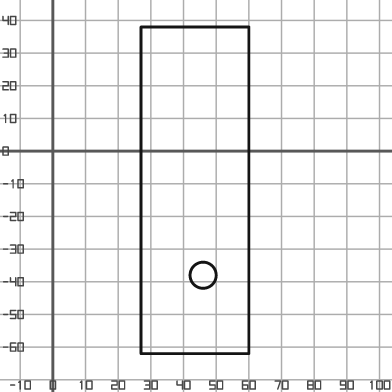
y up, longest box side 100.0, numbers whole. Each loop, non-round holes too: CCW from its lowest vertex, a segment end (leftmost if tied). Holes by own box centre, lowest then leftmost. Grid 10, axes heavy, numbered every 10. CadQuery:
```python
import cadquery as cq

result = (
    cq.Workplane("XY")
    .moveTo(27.0, -62.0)
    .lineTo(60.0, -62.0)
    .lineTo(60.0, 38.0)
    .lineTo(27.0, 38.0)
    .close()
    .moveTo(46.0, -38.0)
    .circle(4.0)
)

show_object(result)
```